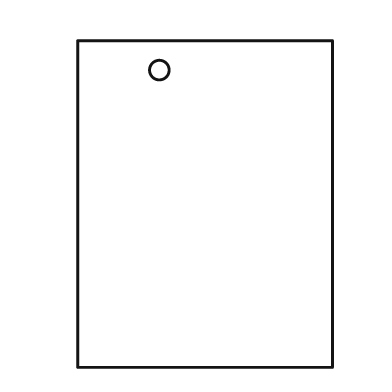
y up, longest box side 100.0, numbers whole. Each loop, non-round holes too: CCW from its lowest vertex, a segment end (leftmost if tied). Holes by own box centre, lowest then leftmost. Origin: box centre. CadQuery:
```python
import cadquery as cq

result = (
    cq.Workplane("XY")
    .moveTo(-39.0, -50.0)
    .lineTo(39.0, -50.0)
    .lineTo(39.0, 50.0)
    .lineTo(-39.0, 50.0)
    .close()
    .moveTo(-14.0, 41.0)
    .circle(3.0)
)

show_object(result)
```